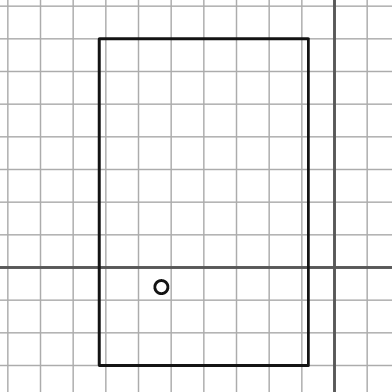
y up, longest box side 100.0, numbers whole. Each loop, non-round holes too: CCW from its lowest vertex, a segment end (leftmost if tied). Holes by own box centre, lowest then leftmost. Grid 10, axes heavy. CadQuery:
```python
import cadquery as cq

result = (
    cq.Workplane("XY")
    .moveTo(-72.0, -30.0)
    .lineTo(-8.0, -30.0)
    .lineTo(-8.0, 70.0)
    .lineTo(-72.0, 70.0)
    .close()
    .moveTo(-53.0, -6.0)
    .circle(2.0)
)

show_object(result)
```